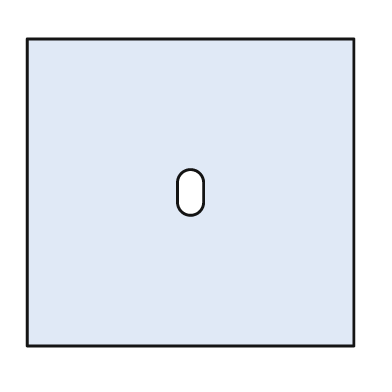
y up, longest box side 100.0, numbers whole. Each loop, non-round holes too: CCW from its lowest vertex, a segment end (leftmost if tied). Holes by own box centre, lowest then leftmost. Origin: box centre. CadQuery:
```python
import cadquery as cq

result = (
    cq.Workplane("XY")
    .moveTo(-50.0, -47.0)
    .lineTo(50.0, -47.0)
    .lineTo(50.0, 47.0)
    .lineTo(-50.0, 47.0)
    .close()
    .moveTo(-4.0, -3.0)
    .threePointArc((0.0, -7.0), (4.0, -3.0))
    .lineTo(4.0, 3.0)
    .threePointArc((0.0, 7.0), (-4.0, 3.0))
    .close()
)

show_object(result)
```